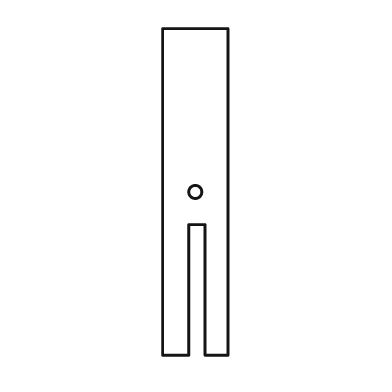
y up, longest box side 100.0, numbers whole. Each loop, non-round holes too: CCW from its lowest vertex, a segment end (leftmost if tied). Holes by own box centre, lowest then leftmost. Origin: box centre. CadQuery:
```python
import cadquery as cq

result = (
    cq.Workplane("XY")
    .moveTo(-10.0, -50.0)
    .lineTo(-2.0, -50.0)
    .lineTo(-2.0, -10.0)
    .lineTo(3.0, -10.0)
    .lineTo(3.0, -50.0)
    .lineTo(10.0, -50.0)
    .lineTo(10.0, 50.0)
    .lineTo(-10.0, 50.0)
    .close()
    .moveTo(0.0, 0.0)
    .circle(2.0)
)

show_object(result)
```